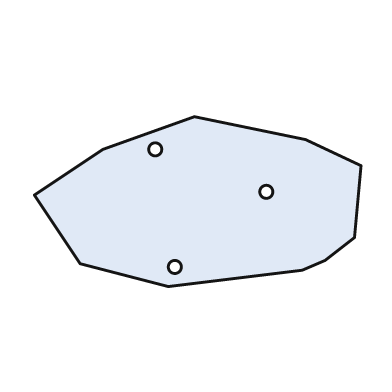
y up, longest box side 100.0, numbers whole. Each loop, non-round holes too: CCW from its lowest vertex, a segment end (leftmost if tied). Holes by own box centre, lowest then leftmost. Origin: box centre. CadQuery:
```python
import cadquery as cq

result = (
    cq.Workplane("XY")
    .moveTo(-9.0, -26.0)
    .lineTo(32.0, -21.0)
    .lineTo(39.0, -18.0)
    .lineTo(48.0, -11.0)
    .lineTo(50.0, 11.0)
    .lineTo(33.0, 19.0)
    .lineTo(-1.0, 26.0)
    .lineTo(-29.0, 16.0)
    .lineTo(-50.0, 2.0)
    .lineTo(-36.0, -19.0)
    .close()
    .moveTo(-7.0, -20.0)
    .circle(2.0)
    .moveTo(21.0, 3.0)
    .circle(2.0)
    .moveTo(-13.0, 16.0)
    .circle(2.0)
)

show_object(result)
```